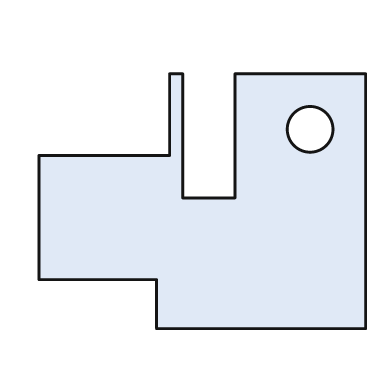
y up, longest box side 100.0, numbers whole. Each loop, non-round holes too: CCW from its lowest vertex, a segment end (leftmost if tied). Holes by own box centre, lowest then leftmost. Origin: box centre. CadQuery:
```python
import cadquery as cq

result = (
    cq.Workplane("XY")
    .moveTo(-14.0, -39.0)
    .lineTo(50.0, -39.0)
    .lineTo(50.0, 39.0)
    .lineTo(10.0, 39.0)
    .lineTo(10.0, 1.0)
    .lineTo(-6.0, 1.0)
    .lineTo(-6.0, 39.0)
    .lineTo(-10.0, 39.0)
    .lineTo(-10.0, 14.0)
    .lineTo(-50.0, 14.0)
    .lineTo(-50.0, -24.0)
    .lineTo(-14.0, -24.0)
    .close()
    .moveTo(33.0, 22.0)
    .circle(7.0)
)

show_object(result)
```